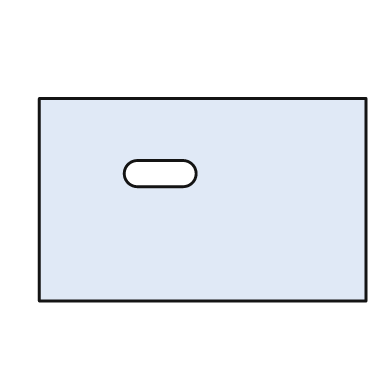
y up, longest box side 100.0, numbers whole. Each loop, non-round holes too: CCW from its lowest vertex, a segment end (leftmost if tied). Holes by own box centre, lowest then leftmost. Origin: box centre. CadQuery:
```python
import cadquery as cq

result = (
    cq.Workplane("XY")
    .moveTo(-50.0, -31.0)
    .lineTo(50.0, -31.0)
    .lineTo(50.0, 31.0)
    .lineTo(-50.0, 31.0)
    .close()
    .moveTo(-20.0, 4.0)
    .lineTo(-6.0, 4.0)
    .threePointArc((-2.0, 8.0), (-6.0, 12.0))
    .lineTo(-20.0, 12.0)
    .threePointArc((-24.0, 8.0), (-20.0, 4.0))
    .close()
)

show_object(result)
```